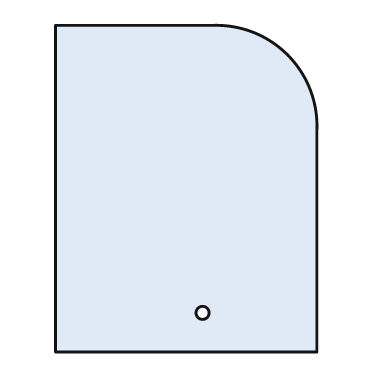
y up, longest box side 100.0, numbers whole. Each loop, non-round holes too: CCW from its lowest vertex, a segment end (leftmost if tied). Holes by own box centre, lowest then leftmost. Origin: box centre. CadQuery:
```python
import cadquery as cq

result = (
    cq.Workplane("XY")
    .moveTo(-40.0, -50.0)
    .lineTo(40.0, -50.0)
    .lineTo(40.0, 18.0)
    .threePointArc((31.0, 41.0), (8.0, 50.0))
    .lineTo(-40.0, 50.0)
    .close()
    .moveTo(5.0, -38.0)
    .circle(2.0)
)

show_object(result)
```